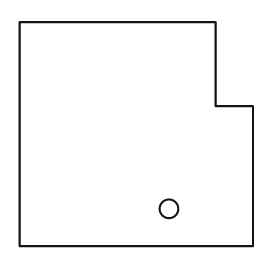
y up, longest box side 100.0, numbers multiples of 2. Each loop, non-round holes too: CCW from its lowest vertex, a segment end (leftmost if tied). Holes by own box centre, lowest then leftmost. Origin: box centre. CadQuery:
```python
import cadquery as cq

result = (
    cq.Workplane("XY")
    .moveTo(-50.0, -48.0)
    .lineTo(50.0, -48.0)
    .lineTo(50.0, 12.0)
    .lineTo(34.0, 12.0)
    .lineTo(34.0, 48.0)
    .lineTo(-50.0, 48.0)
    .close()
    .moveTo(14.0, -32.0)
    .circle(4.0)
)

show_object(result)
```